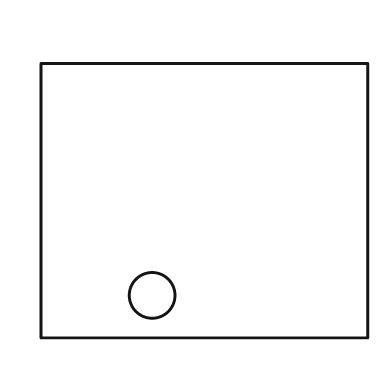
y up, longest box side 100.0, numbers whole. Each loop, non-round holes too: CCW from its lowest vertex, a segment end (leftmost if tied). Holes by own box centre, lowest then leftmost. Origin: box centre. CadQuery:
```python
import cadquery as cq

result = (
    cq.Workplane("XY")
    .moveTo(-50.0, -42.0)
    .lineTo(50.0, -42.0)
    .lineTo(50.0, 42.0)
    .lineTo(-50.0, 42.0)
    .close()
    .moveTo(-16.0, -29.0)
    .circle(7.0)
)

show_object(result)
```